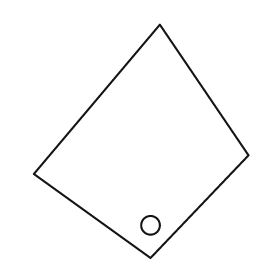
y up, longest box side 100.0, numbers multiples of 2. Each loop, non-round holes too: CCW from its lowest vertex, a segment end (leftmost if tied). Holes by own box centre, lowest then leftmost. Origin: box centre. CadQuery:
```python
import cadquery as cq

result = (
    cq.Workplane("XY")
    .moveTo(4.0, -50.0)
    .lineTo(46.0, -6.0)
    .lineTo(8.0, 50.0)
    .lineTo(-46.0, -14.0)
    .close()
    .moveTo(4.0, -36.0)
    .circle(4.0)
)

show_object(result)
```